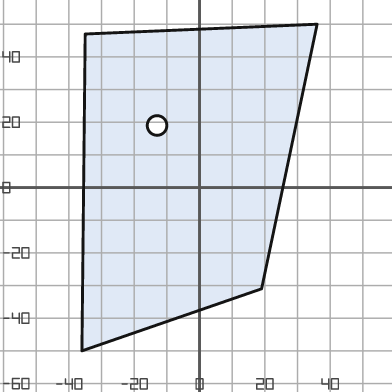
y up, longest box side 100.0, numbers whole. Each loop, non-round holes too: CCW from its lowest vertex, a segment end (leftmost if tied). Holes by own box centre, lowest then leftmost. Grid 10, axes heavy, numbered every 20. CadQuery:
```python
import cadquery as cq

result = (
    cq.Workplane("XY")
    .moveTo(-36.0, -50.0)
    .lineTo(19.0, -31.0)
    .lineTo(36.0, 50.0)
    .lineTo(-35.0, 47.0)
    .close()
    .moveTo(-13.0, 19.0)
    .circle(3.0)
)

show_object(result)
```